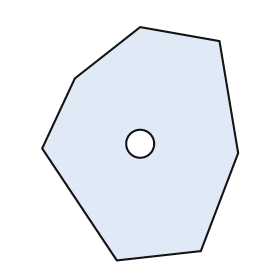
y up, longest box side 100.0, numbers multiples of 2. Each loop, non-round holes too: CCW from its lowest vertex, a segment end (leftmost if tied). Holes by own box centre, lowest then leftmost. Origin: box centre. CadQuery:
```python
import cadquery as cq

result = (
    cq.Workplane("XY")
    .moveTo(-10.0, -50.0)
    .lineTo(26.0, -46.0)
    .lineTo(42.0, -4.0)
    .lineTo(34.0, 44.0)
    .lineTo(0.0, 50.0)
    .lineTo(-28.0, 28.0)
    .lineTo(-42.0, -2.0)
    .close()
    .moveTo(0.0, 0.0)
    .circle(6.0)
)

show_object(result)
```